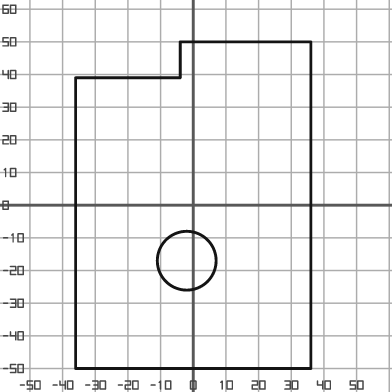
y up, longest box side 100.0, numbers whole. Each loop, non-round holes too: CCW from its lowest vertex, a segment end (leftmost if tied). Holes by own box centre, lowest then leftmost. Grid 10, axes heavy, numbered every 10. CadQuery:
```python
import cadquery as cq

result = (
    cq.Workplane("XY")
    .moveTo(-36.0, -50.0)
    .lineTo(36.0, -50.0)
    .lineTo(36.0, 50.0)
    .lineTo(-4.0, 50.0)
    .lineTo(-4.0, 39.0)
    .lineTo(-36.0, 39.0)
    .close()
    .moveTo(-2.0, -17.0)
    .circle(9.0)
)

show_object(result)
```